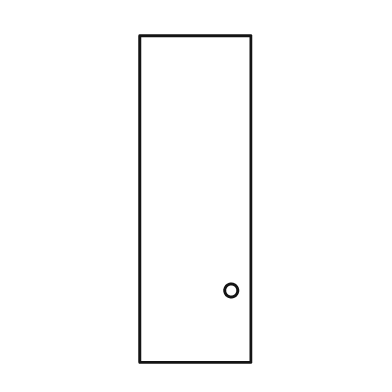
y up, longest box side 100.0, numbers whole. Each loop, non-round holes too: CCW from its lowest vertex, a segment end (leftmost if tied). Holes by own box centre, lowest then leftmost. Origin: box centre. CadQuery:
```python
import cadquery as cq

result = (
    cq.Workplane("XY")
    .moveTo(-17.0, -50.0)
    .lineTo(17.0, -50.0)
    .lineTo(17.0, 50.0)
    .lineTo(-17.0, 50.0)
    .close()
    .moveTo(11.0, -28.0)
    .circle(2.0)
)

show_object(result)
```